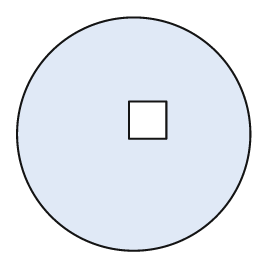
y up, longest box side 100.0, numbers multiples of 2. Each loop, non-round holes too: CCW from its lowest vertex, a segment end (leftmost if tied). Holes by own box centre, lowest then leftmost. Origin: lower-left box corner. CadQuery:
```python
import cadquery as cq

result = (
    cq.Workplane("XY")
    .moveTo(50.0, 50.0)
    .circle(50.0)
    .moveTo(48.0, 48.0)
    .lineTo(64.0, 48.0)
    .lineTo(64.0, 64.0)
    .lineTo(48.0, 64.0)
    .close()
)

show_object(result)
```